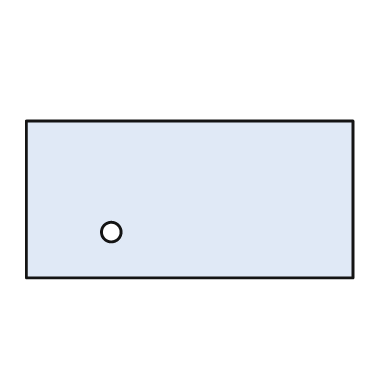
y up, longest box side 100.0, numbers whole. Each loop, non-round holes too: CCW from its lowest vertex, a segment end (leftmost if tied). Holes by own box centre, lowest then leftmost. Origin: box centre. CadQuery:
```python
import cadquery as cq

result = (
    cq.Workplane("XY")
    .moveTo(-50.0, -24.0)
    .lineTo(50.0, -24.0)
    .lineTo(50.0, 24.0)
    .lineTo(-50.0, 24.0)
    .close()
    .moveTo(-24.0, -10.0)
    .circle(3.0)
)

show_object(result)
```